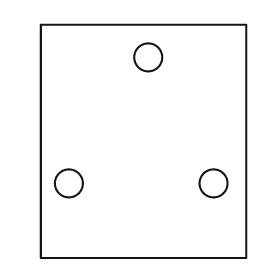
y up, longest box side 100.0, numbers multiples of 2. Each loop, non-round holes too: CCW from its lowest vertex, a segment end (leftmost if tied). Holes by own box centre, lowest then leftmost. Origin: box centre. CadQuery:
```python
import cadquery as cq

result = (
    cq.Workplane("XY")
    .moveTo(-44.0, -50.0)
    .lineTo(44.0, -50.0)
    .lineTo(44.0, 50.0)
    .lineTo(-44.0, 50.0)
    .close()
    .moveTo(-32.0, -18.0)
    .circle(6.0)
    .moveTo(30.0, -18.0)
    .circle(6.0)
    .moveTo(2.0, 36.0)
    .circle(6.0)
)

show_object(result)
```